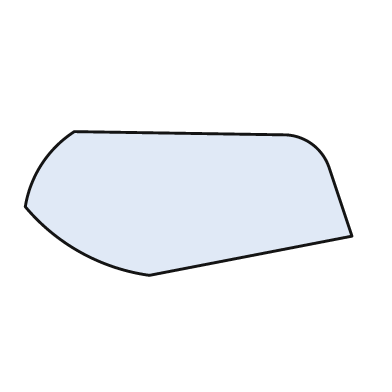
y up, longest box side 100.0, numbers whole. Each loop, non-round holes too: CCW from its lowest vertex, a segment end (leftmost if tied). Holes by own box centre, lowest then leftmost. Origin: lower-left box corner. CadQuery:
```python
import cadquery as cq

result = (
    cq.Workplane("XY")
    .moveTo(38.0, 0.0)
    .lineTo(100.0, 12.0)
    .lineTo(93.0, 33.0)
    .threePointArc((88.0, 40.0), (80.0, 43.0))
    .lineTo(15.0, 44.0)
    .threePointArc((5.0, 34.0), (0.0, 21.0))
    .threePointArc((17.0, 7.0), (38.0, 0.0))
    .close()
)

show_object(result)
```